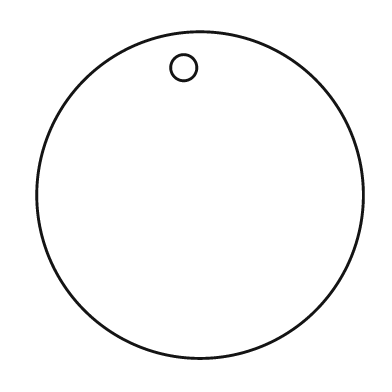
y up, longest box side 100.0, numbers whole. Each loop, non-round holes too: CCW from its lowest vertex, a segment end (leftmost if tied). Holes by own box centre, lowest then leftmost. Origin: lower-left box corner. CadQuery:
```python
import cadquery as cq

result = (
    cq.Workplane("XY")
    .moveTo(50.0, 50.0)
    .circle(50.0)
    .moveTo(45.0, 89.0)
    .circle(4.0)
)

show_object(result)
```